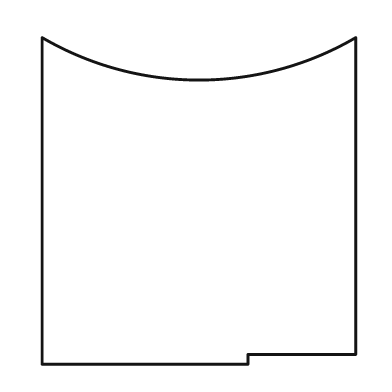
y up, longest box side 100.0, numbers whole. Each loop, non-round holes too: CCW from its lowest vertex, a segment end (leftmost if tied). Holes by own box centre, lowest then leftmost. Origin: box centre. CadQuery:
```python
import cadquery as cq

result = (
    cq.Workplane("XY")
    .moveTo(-48.0, -50.0)
    .lineTo(15.0, -50.0)
    .lineTo(15.0, -47.0)
    .lineTo(48.0, -47.0)
    .lineTo(48.0, 50.0)
    .threePointArc((0.0, 37.0), (-48.0, 50.0))
    .close()
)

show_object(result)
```